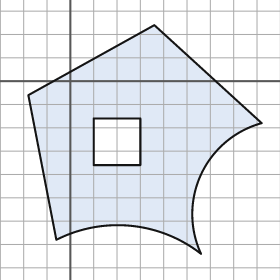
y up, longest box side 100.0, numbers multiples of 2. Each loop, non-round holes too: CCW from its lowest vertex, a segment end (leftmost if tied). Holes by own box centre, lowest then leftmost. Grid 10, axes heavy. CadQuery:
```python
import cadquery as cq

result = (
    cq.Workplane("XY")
    .moveTo(56.0, -74.0)
    .threePointArc((56.0, -40.0), (82.0, -18.0))
    .lineTo(36.0, 24.0)
    .lineTo(-18.0, -6.0)
    .lineTo(-6.0, -68.0)
    .threePointArc((26.0, -62.0), (56.0, -74.0))
    .close()
    .moveTo(10.0, -36.0)
    .lineTo(30.0, -36.0)
    .lineTo(30.0, -16.0)
    .lineTo(10.0, -16.0)
    .close()
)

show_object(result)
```